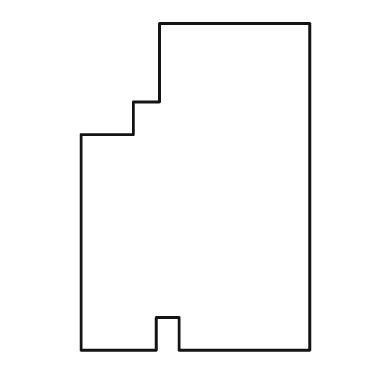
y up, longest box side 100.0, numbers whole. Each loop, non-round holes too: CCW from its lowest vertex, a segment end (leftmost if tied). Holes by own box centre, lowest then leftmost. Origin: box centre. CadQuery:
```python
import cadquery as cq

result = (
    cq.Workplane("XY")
    .moveTo(-35.0, -50.0)
    .lineTo(-12.0, -50.0)
    .lineTo(-12.0, -40.0)
    .lineTo(-5.0, -40.0)
    .lineTo(-5.0, -50.0)
    .lineTo(35.0, -50.0)
    .lineTo(35.0, 50.0)
    .lineTo(-11.0, 50.0)
    .lineTo(-11.0, 26.0)
    .lineTo(-19.0, 26.0)
    .lineTo(-19.0, 16.0)
    .lineTo(-35.0, 16.0)
    .close()
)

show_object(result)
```